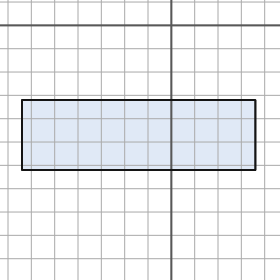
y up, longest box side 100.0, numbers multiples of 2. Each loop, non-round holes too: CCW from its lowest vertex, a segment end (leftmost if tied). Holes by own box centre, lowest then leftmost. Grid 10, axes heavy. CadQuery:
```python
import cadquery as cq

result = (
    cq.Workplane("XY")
    .moveTo(-64.0, -62.0)
    .lineTo(36.0, -62.0)
    .lineTo(36.0, -32.0)
    .lineTo(-64.0, -32.0)
    .close()
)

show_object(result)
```